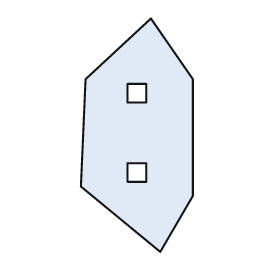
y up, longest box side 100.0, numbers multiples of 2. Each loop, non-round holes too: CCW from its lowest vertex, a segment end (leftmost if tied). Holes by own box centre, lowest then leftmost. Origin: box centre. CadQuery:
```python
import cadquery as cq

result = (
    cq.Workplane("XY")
    .moveTo(10.0, -50.0)
    .lineTo(24.0, -26.0)
    .lineTo(24.0, 24.0)
    .lineTo(6.0, 50.0)
    .lineTo(-22.0, 24.0)
    .lineTo(-24.0, -22.0)
    .close()
    .moveTo(-4.0, -20.0)
    .lineTo(4.0, -20.0)
    .lineTo(4.0, -12.0)
    .lineTo(-4.0, -12.0)
    .close()
    .moveTo(-4.0, 14.0)
    .lineTo(4.0, 14.0)
    .lineTo(4.0, 22.0)
    .lineTo(-4.0, 22.0)
    .close()
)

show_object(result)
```